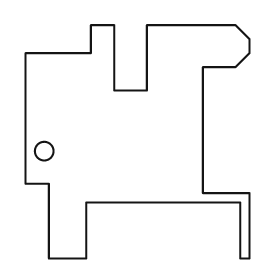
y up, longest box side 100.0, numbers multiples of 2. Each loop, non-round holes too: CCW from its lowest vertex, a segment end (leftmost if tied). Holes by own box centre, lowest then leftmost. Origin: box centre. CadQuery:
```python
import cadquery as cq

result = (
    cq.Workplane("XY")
    .moveTo(-38.0, -50.0)
    .lineTo(-22.0, -50.0)
    .lineTo(-22.0, -26.0)
    .lineTo(44.0, -26.0)
    .lineTo(44.0, -50.0)
    .lineTo(48.0, -50.0)
    .lineTo(48.0, -22.0)
    .lineTo(28.0, -22.0)
    .lineTo(28.0, 32.0)
    .lineTo(42.0, 32.0)
    .lineTo(48.0, 38.0)
    .lineTo(48.0, 44.0)
    .lineTo(42.0, 50.0)
    .lineTo(4.0, 50.0)
    .lineTo(4.0, 22.0)
    .lineTo(-10.0, 22.0)
    .lineTo(-10.0, 50.0)
    .lineTo(-20.0, 50.0)
    .lineTo(-20.0, 38.0)
    .lineTo(-48.0, 38.0)
    .lineTo(-48.0, -18.0)
    .lineTo(-38.0, -18.0)
    .close()
    .moveTo(-40.0, -4.0)
    .circle(4.0)
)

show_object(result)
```